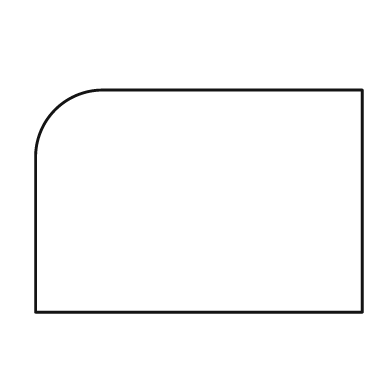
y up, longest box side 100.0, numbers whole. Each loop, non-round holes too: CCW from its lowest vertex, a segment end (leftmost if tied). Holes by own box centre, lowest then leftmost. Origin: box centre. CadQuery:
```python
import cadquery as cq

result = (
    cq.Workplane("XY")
    .moveTo(-50.0, -34.0)
    .lineTo(50.0, -34.0)
    .lineTo(50.0, 34.0)
    .lineTo(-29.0, 34.0)
    .threePointArc((-44.0, 28.0), (-50.0, 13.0))
    .close()
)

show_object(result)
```